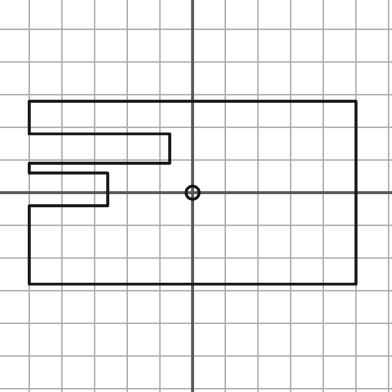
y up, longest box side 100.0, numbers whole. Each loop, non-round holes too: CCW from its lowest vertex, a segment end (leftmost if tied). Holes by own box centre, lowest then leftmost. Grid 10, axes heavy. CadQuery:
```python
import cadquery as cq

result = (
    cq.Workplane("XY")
    .moveTo(-50.0, -28.0)
    .lineTo(50.0, -28.0)
    .lineTo(50.0, 28.0)
    .lineTo(-50.0, 28.0)
    .lineTo(-50.0, 18.0)
    .lineTo(-7.0, 18.0)
    .lineTo(-7.0, 9.0)
    .lineTo(-50.0, 9.0)
    .lineTo(-50.0, 6.0)
    .lineTo(-26.0, 6.0)
    .lineTo(-26.0, -4.0)
    .lineTo(-50.0, -4.0)
    .close()
    .moveTo(0.0, 0.0)
    .circle(2.0)
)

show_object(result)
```